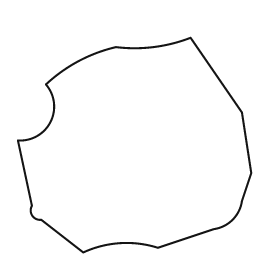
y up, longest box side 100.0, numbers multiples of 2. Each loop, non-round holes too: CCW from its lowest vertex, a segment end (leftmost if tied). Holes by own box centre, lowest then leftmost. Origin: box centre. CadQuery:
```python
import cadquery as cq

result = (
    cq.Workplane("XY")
    .moveTo(-22.0, -46.0)
    .threePointArc((-6.0, -42.0), (10.0, -44.0))
    .lineTo(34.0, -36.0)
    .threePointArc((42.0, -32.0), (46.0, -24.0))
    .lineTo(50.0, -12.0)
    .lineTo(46.0, 14.0)
    .lineTo(24.0, 46.0)
    .threePointArc((8.0, 42.0), (-8.0, 42.0))
    .threePointArc((-24.0, 36.0), (-38.0, 26.0))
    .threePointArc((-36.0, 10.0), (-50.0, 2.0))
    .lineTo(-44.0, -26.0)
    .threePointArc((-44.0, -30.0), (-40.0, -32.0))
    .close()
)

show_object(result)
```